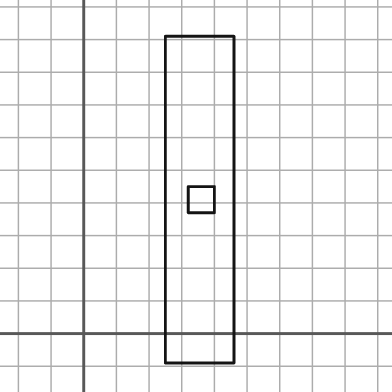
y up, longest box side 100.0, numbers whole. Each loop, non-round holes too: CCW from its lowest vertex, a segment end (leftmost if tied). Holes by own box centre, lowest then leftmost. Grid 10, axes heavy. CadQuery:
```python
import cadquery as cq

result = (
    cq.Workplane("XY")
    .moveTo(25.0, -9.0)
    .lineTo(46.0, -9.0)
    .lineTo(46.0, 91.0)
    .lineTo(25.0, 91.0)
    .close()
    .moveTo(32.0, 37.0)
    .lineTo(40.0, 37.0)
    .lineTo(40.0, 45.0)
    .lineTo(32.0, 45.0)
    .close()
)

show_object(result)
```